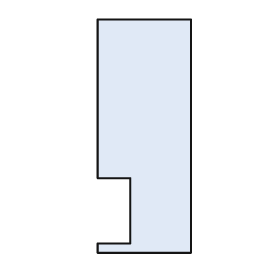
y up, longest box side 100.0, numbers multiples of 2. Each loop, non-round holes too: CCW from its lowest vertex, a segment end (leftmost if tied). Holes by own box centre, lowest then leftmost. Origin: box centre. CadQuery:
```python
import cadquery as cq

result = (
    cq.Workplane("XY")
    .moveTo(-20.0, -50.0)
    .lineTo(20.0, -50.0)
    .lineTo(20.0, 50.0)
    .lineTo(-20.0, 50.0)
    .lineTo(-20.0, -18.0)
    .lineTo(-6.0, -18.0)
    .lineTo(-6.0, -46.0)
    .lineTo(-20.0, -46.0)
    .close()
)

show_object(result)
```